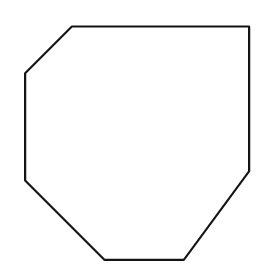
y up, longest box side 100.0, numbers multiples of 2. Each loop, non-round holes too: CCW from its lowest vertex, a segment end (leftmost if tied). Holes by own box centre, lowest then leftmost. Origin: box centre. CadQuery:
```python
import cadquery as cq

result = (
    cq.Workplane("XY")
    .moveTo(-14.0, -50.0)
    .lineTo(20.0, -50.0)
    .lineTo(48.0, -12.0)
    .lineTo(48.0, 50.0)
    .lineTo(-28.0, 50.0)
    .lineTo(-48.0, 30.0)
    .lineTo(-48.0, -16.0)
    .close()
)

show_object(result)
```